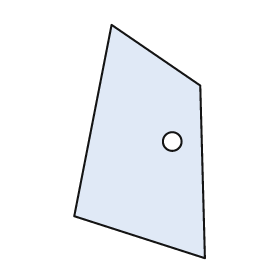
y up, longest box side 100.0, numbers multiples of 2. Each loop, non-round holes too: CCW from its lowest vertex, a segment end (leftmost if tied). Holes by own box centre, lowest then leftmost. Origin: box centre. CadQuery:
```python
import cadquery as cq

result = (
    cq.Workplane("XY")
    .moveTo(28.0, -50.0)
    .lineTo(26.0, 24.0)
    .lineTo(-12.0, 50.0)
    .lineTo(-28.0, -32.0)
    .close()
    .moveTo(14.0, 0.0)
    .circle(4.0)
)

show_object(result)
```